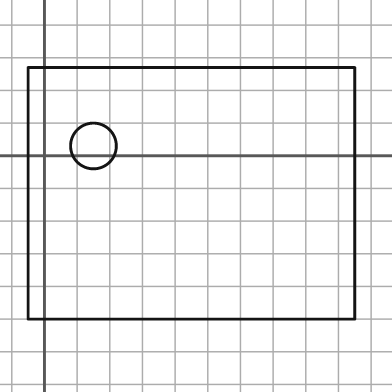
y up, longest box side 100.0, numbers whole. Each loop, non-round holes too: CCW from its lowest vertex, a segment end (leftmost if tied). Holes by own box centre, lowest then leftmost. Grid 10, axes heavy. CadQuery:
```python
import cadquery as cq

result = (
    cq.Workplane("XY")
    .moveTo(-5.0, -50.0)
    .lineTo(95.0, -50.0)
    .lineTo(95.0, 27.0)
    .lineTo(-5.0, 27.0)
    .close()
    .moveTo(15.0, 3.0)
    .circle(7.0)
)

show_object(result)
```